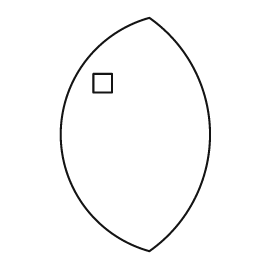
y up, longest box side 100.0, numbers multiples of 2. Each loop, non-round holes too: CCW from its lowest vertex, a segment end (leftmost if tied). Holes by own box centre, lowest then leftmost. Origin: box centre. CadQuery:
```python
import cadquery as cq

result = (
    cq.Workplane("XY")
    .moveTo(6.0, -50.0)
    .threePointArc((32.0, 0.0), (6.0, 50.0))
    .threePointArc((-32.0, 0.0), (6.0, -50.0))
    .close()
    .moveTo(-18.0, 18.0)
    .lineTo(-10.0, 18.0)
    .lineTo(-10.0, 26.0)
    .lineTo(-18.0, 26.0)
    .close()
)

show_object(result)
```